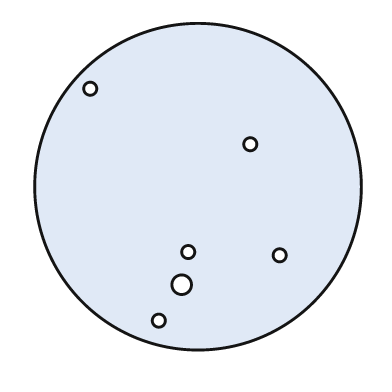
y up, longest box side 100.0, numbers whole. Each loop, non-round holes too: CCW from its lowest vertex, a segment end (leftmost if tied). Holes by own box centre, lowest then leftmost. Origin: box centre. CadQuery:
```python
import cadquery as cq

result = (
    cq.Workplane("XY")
    .moveTo(0.0, 0.0)
    .circle(50.0)
    .moveTo(-12.0, -41.0)
    .circle(2.0)
    .moveTo(-5.0, -30.0)
    .circle(3.0)
    .moveTo(25.0, -21.0)
    .circle(2.0)
    .moveTo(-3.0, -20.0)
    .circle(2.0)
    .moveTo(16.0, 13.0)
    .circle(2.0)
    .moveTo(-33.0, 30.0)
    .circle(2.0)
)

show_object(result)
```